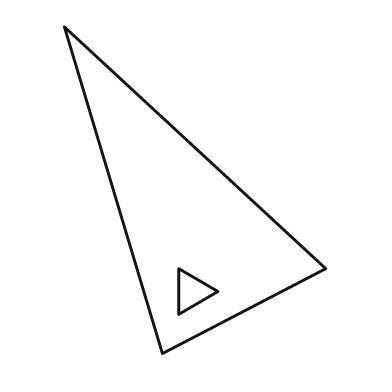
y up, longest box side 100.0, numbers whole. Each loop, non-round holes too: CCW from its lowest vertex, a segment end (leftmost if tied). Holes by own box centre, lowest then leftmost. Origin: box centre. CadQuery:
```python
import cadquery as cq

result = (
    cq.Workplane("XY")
    .moveTo(-10.0, -50.0)
    .lineTo(40.0, -24.0)
    .lineTo(-40.0, 50.0)
    .close()
    .moveTo(-5.0, -38.0)
    .lineTo(7.0, -31.0)
    .lineTo(-5.0, -24.0)
    .close()
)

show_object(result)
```